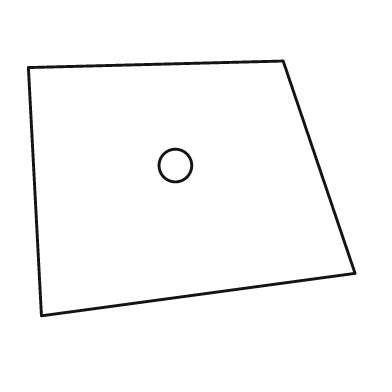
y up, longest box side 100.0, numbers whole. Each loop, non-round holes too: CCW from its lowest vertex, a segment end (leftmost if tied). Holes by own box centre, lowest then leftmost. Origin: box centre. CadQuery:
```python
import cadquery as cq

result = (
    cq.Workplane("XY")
    .moveTo(-46.0, -39.0)
    .lineTo(50.0, -26.0)
    .lineTo(28.0, 39.0)
    .lineTo(-50.0, 37.0)
    .close()
    .moveTo(-5.0, 7.0)
    .circle(5.0)
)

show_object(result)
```